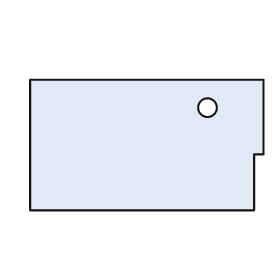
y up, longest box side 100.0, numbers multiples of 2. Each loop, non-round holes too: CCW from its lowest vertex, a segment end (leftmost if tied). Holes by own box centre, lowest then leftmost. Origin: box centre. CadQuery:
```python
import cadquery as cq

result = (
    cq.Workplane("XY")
    .moveTo(-50.0, -28.0)
    .lineTo(46.0, -28.0)
    .lineTo(46.0, -4.0)
    .lineTo(50.0, -4.0)
    .lineTo(50.0, 28.0)
    .lineTo(-50.0, 28.0)
    .close()
    .moveTo(26.0, 16.0)
    .circle(4.0)
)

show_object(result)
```